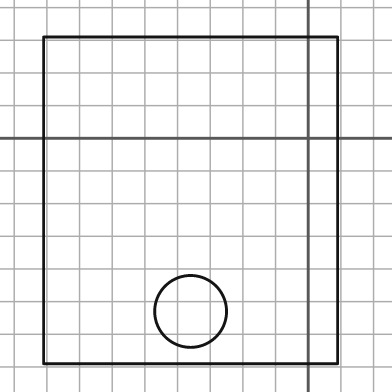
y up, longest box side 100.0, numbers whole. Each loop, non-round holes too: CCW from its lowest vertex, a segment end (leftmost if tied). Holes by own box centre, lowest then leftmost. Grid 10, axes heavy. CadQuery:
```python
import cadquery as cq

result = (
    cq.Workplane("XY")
    .moveTo(-81.0, -69.0)
    .lineTo(9.0, -69.0)
    .lineTo(9.0, 31.0)
    .lineTo(-81.0, 31.0)
    .close()
    .moveTo(-36.0, -53.0)
    .circle(11.0)
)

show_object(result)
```